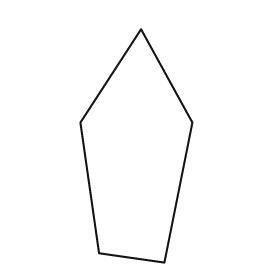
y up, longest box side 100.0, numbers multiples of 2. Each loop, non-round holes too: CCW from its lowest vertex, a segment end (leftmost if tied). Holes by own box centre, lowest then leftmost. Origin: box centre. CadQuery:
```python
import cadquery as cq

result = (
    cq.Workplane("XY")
    .moveTo(12.0, -50.0)
    .lineTo(24.0, 10.0)
    .lineTo(2.0, 50.0)
    .lineTo(-24.0, 10.0)
    .lineTo(-16.0, -46.0)
    .close()
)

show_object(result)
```